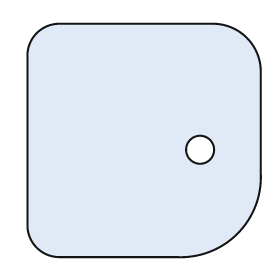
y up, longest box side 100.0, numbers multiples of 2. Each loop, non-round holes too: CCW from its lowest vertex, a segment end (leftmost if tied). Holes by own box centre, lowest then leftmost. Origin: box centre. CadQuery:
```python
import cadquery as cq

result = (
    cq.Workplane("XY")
    .moveTo(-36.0, -50.0)
    .lineTo(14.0, -50.0)
    .threePointArc((40.0, -40.0), (50.0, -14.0))
    .lineTo(50.0, 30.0)
    .threePointArc((44.0, 44.0), (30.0, 50.0))
    .lineTo(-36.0, 50.0)
    .threePointArc((-46.0, 46.0), (-50.0, 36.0))
    .lineTo(-50.0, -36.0)
    .threePointArc((-46.0, -46.0), (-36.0, -50.0))
    .close()
    .moveTo(24.0, -4.0)
    .circle(6.0)
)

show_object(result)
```